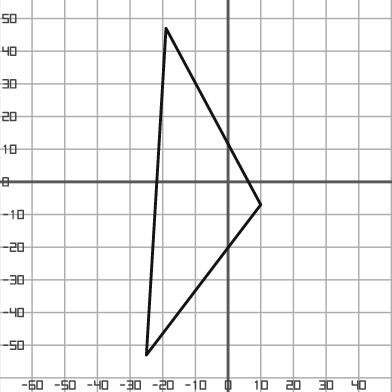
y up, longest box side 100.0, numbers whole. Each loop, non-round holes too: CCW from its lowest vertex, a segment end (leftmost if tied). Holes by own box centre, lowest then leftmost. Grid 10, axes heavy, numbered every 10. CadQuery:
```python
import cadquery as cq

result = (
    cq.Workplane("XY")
    .moveTo(-25.0, -53.0)
    .lineTo(10.0, -7.0)
    .lineTo(-19.0, 47.0)
    .close()
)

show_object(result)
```